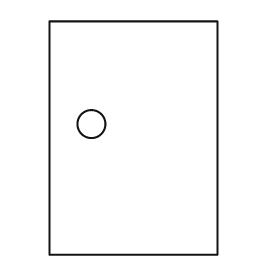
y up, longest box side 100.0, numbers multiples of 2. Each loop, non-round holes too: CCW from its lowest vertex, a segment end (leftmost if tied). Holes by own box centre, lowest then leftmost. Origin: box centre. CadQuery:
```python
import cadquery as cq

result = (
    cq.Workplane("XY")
    .moveTo(-36.0, -50.0)
    .lineTo(36.0, -50.0)
    .lineTo(36.0, 50.0)
    .lineTo(-36.0, 50.0)
    .close()
    .moveTo(-18.0, 6.0)
    .circle(6.0)
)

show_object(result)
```